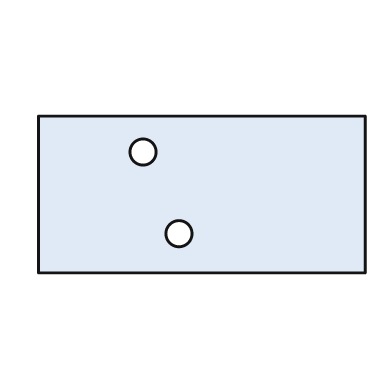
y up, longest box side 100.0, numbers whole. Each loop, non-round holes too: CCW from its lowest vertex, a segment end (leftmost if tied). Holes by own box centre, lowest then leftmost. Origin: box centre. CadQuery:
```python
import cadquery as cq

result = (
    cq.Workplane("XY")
    .moveTo(-50.0, -24.0)
    .lineTo(50.0, -24.0)
    .lineTo(50.0, 24.0)
    .lineTo(-50.0, 24.0)
    .close()
    .moveTo(-7.0, -12.0)
    .circle(4.0)
    .moveTo(-18.0, 13.0)
    .circle(4.0)
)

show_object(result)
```